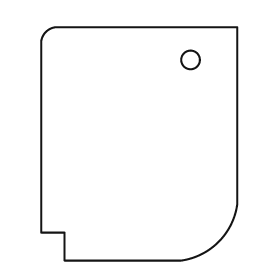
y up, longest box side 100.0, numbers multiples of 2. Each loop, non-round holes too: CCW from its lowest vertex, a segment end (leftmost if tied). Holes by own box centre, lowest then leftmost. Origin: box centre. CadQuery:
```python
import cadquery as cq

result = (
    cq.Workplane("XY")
    .moveTo(-32.0, -50.0)
    .lineTo(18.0, -50.0)
    .threePointArc((34.0, -42.0), (42.0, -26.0))
    .lineTo(42.0, 50.0)
    .lineTo(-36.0, 50.0)
    .threePointArc((-40.0, 48.0), (-42.0, 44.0))
    .lineTo(-42.0, -38.0)
    .lineTo(-32.0, -38.0)
    .close()
    .moveTo(22.0, 36.0)
    .circle(4.0)
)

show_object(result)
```